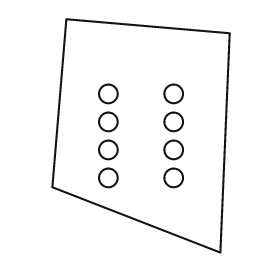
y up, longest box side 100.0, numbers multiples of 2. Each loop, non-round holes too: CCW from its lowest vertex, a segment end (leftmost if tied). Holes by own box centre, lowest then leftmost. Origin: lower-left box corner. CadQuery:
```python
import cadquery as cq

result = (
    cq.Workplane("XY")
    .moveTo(72.0, 0.0)
    .lineTo(76.0, 94.0)
    .lineTo(6.0, 100.0)
    .lineTo(0.0, 28.0)
    .close()
    .moveTo(24.0, 32.0)
    .circle(4.0)
    .moveTo(52.0, 32.0)
    .circle(4.0)
    .moveTo(24.0, 44.0)
    .circle(4.0)
    .moveTo(52.0, 44.0)
    .circle(4.0)
    .moveTo(24.0, 56.0)
    .circle(4.0)
    .moveTo(52.0, 56.0)
    .circle(4.0)
    .moveTo(24.0, 68.0)
    .circle(4.0)
    .moveTo(52.0, 68.0)
    .circle(4.0)
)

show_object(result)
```